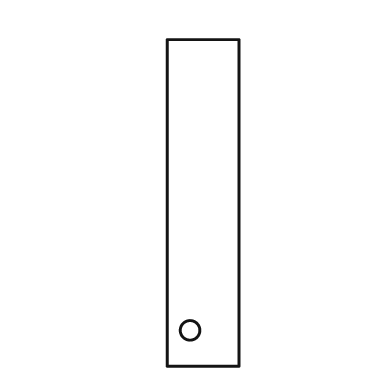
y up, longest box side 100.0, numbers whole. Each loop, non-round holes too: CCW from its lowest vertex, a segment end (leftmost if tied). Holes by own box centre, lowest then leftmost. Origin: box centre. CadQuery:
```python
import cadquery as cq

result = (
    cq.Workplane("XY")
    .moveTo(-11.0, -50.0)
    .lineTo(11.0, -50.0)
    .lineTo(11.0, 50.0)
    .lineTo(-11.0, 50.0)
    .close()
    .moveTo(-4.0, -39.0)
    .circle(3.0)
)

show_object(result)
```